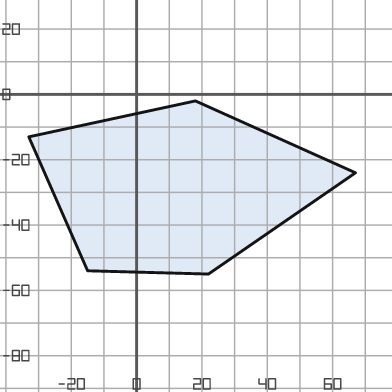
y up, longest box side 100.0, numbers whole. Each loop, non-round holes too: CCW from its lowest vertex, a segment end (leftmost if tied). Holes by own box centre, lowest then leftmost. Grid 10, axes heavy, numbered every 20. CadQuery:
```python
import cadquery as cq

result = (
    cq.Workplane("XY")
    .moveTo(22.0, -55.0)
    .lineTo(67.0, -24.0)
    .lineTo(18.0, -2.0)
    .lineTo(-33.0, -13.0)
    .lineTo(-15.0, -54.0)
    .close()
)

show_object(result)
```